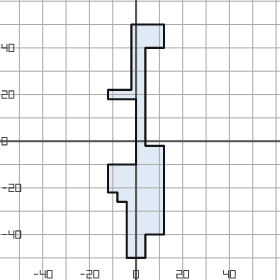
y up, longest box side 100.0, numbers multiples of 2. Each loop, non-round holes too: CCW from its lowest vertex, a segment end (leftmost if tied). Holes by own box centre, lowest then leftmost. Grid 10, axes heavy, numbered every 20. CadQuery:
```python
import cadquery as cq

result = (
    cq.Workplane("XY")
    .moveTo(-4.0, -50.0)
    .lineTo(4.0, -50.0)
    .lineTo(4.0, -40.0)
    .lineTo(12.0, -40.0)
    .lineTo(12.0, -2.0)
    .lineTo(4.0, -2.0)
    .lineTo(4.0, 40.0)
    .lineTo(12.0, 40.0)
    .lineTo(12.0, 50.0)
    .lineTo(-2.0, 50.0)
    .lineTo(-2.0, 22.0)
    .lineTo(-12.0, 22.0)
    .lineTo(-12.0, 18.0)
    .lineTo(0.0, 18.0)
    .lineTo(0.0, -10.0)
    .lineTo(-12.0, -10.0)
    .lineTo(-12.0, -22.0)
    .lineTo(-8.0, -22.0)
    .lineTo(-8.0, -26.0)
    .lineTo(-4.0, -26.0)
    .close()
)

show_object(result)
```